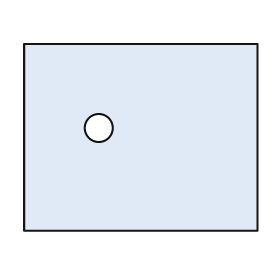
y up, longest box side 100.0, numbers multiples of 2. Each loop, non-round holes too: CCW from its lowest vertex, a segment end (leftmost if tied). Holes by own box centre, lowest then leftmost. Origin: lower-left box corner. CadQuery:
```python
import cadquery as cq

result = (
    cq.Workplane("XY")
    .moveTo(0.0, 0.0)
    .lineTo(100.0, 0.0)
    .lineTo(100.0, 80.0)
    .lineTo(0.0, 80.0)
    .close()
    .moveTo(32.0, 44.0)
    .circle(6.0)
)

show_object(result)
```